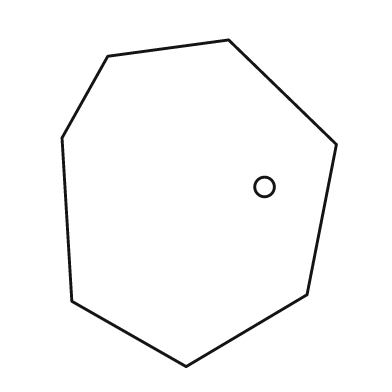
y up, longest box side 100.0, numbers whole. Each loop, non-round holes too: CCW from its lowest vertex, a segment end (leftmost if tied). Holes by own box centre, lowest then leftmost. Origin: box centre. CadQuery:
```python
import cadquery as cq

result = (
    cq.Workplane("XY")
    .moveTo(-4.0, -50.0)
    .lineTo(33.0, -28.0)
    .lineTo(42.0, 18.0)
    .lineTo(9.0, 50.0)
    .lineTo(-28.0, 45.0)
    .lineTo(-42.0, 20.0)
    .lineTo(-39.0, -30.0)
    .close()
    .moveTo(20.0, 5.0)
    .circle(3.0)
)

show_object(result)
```